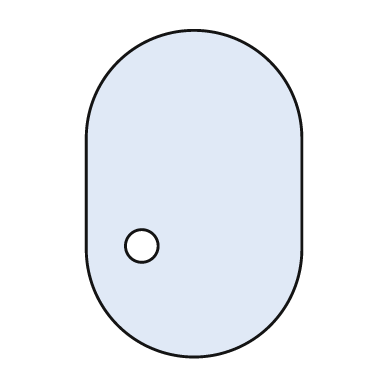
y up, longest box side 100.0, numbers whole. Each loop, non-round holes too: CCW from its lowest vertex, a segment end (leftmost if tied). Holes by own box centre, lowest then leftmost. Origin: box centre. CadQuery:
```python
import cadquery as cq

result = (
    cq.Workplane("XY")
    .moveTo(-33.0, -17.0)
    .threePointArc((0.0, -50.0), (33.0, -17.0))
    .lineTo(33.0, 17.0)
    .threePointArc((0.0, 50.0), (-33.0, 17.0))
    .close()
    .moveTo(-16.0, -16.0)
    .circle(5.0)
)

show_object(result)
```